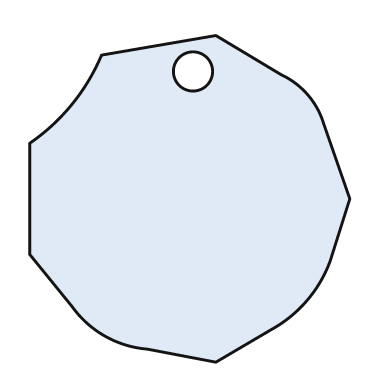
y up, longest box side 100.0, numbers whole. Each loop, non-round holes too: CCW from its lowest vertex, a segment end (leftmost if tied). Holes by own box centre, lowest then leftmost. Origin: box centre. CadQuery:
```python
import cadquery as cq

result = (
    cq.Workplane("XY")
    .moveTo(8.0, -50.0)
    .lineTo(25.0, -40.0)
    .threePointArc((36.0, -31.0), (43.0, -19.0))
    .lineTo(49.0, 0.0)
    .lineTo(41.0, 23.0)
    .threePointArc((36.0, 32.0), (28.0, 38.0))
    .lineTo(8.0, 50.0)
    .lineTo(-27.0, 44.0)
    .threePointArc((-36.0, 29.0), (-49.0, 17.0))
    .lineTo(-49.0, -17.0)
    .lineTo(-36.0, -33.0)
    .threePointArc((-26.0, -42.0), (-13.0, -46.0))
    .close()
    .moveTo(1.0, 39.0)
    .circle(6.0)
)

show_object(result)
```